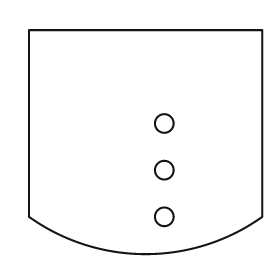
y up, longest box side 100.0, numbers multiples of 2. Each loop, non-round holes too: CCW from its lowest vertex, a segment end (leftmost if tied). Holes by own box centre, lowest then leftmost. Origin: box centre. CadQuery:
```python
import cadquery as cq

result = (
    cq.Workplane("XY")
    .moveTo(-50.0, -32.0)
    .threePointArc((0.0, -48.0), (50.0, -32.0))
    .lineTo(50.0, 48.0)
    .lineTo(-50.0, 48.0)
    .close()
    .moveTo(8.0, -32.0)
    .circle(4.0)
    .moveTo(8.0, -12.0)
    .circle(4.0)
    .moveTo(8.0, 8.0)
    .circle(4.0)
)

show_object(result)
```